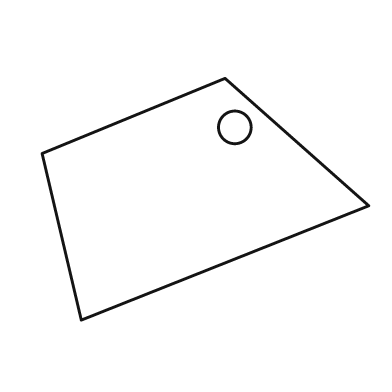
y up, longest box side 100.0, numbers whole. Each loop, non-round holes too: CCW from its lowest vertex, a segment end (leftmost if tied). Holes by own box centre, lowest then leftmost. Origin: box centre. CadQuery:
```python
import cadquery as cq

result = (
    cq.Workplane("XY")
    .moveTo(-38.0, -37.0)
    .lineTo(50.0, -2.0)
    .lineTo(6.0, 37.0)
    .lineTo(-50.0, 14.0)
    .close()
    .moveTo(9.0, 22.0)
    .circle(5.0)
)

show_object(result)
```